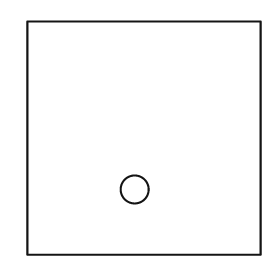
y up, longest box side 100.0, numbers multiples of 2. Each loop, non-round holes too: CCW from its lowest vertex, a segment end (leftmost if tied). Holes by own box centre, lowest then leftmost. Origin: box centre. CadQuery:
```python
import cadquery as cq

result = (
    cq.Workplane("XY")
    .moveTo(-50.0, -50.0)
    .lineTo(50.0, -50.0)
    .lineTo(50.0, 50.0)
    .lineTo(-50.0, 50.0)
    .close()
    .moveTo(-4.0, -22.0)
    .circle(6.0)
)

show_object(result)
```